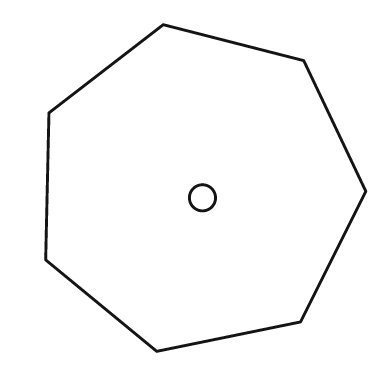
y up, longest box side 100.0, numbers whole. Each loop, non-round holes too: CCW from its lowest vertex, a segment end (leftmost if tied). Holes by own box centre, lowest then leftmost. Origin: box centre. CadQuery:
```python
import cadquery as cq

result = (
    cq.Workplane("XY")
    .moveTo(-15.0, -50.0)
    .lineTo(29.0, -41.0)
    .lineTo(49.0, -1.0)
    .lineTo(30.0, 39.0)
    .lineTo(-13.0, 50.0)
    .lineTo(-48.0, 23.0)
    .lineTo(-49.0, -22.0)
    .close()
    .moveTo(-1.0, -3.0)
    .circle(4.0)
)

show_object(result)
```